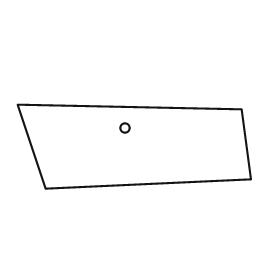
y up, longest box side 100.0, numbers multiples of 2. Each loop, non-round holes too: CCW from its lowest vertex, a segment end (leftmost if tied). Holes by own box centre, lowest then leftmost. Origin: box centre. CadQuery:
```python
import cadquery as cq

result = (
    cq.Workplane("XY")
    .moveTo(-38.0, -18.0)
    .lineTo(50.0, -14.0)
    .lineTo(46.0, 16.0)
    .lineTo(-50.0, 18.0)
    .close()
    .moveTo(-4.0, 8.0)
    .circle(2.0)
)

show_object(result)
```